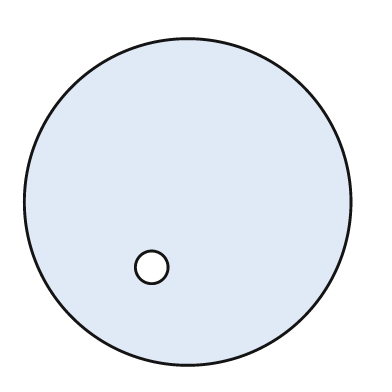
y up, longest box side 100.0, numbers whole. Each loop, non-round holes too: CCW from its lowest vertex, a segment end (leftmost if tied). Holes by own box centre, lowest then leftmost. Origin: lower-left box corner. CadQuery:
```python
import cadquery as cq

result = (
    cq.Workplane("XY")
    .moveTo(50.0, 50.0)
    .circle(50.0)
    .moveTo(39.0, 30.0)
    .circle(5.0)
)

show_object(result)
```